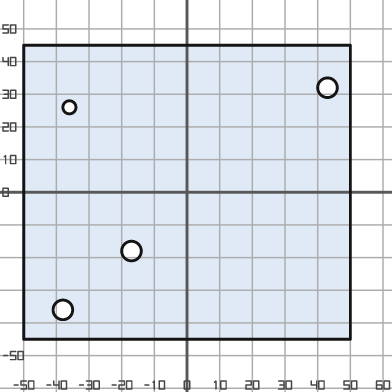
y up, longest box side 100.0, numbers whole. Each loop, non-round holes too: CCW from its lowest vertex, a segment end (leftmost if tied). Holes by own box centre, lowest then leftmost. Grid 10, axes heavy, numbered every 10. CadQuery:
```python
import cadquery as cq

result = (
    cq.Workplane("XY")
    .moveTo(-50.0, -45.0)
    .lineTo(50.0, -45.0)
    .lineTo(50.0, 45.0)
    .lineTo(-50.0, 45.0)
    .close()
    .moveTo(-38.0, -36.0)
    .circle(3.0)
    .moveTo(-17.0, -18.0)
    .circle(3.0)
    .moveTo(-36.0, 26.0)
    .circle(2.0)
    .moveTo(43.0, 32.0)
    .circle(3.0)
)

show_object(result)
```